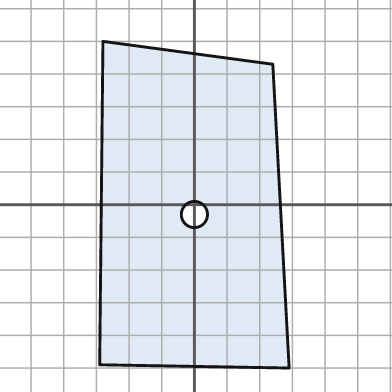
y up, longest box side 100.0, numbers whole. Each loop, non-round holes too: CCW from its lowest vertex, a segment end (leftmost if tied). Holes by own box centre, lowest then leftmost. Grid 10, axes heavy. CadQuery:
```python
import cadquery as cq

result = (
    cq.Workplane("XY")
    .moveTo(29.0, -50.0)
    .lineTo(24.0, 43.0)
    .lineTo(-28.0, 50.0)
    .lineTo(-29.0, -49.0)
    .close()
    .moveTo(0.0, -3.0)
    .circle(4.0)
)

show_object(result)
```